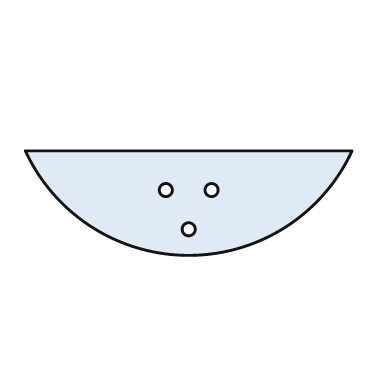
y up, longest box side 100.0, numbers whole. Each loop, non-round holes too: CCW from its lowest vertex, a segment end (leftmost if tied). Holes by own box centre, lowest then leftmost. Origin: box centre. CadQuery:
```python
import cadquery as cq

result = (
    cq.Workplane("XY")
    .moveTo(-50.0, 16.0)
    .threePointArc((0.0, -16.0), (50.0, 16.0))
    .close()
    .moveTo(0.0, -8.0)
    .circle(2.0)
    .moveTo(-7.0, 4.0)
    .circle(2.0)
    .moveTo(7.0, 4.0)
    .circle(2.0)
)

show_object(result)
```